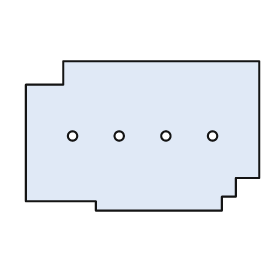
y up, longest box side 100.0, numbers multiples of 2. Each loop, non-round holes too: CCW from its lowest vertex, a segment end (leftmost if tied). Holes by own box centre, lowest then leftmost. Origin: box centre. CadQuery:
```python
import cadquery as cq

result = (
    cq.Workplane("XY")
    .moveTo(-20.0, -32.0)
    .lineTo(34.0, -32.0)
    .lineTo(34.0, -26.0)
    .lineTo(40.0, -26.0)
    .lineTo(40.0, -18.0)
    .lineTo(50.0, -18.0)
    .lineTo(50.0, 32.0)
    .lineTo(-34.0, 32.0)
    .lineTo(-34.0, 22.0)
    .lineTo(-50.0, 22.0)
    .lineTo(-50.0, -28.0)
    .lineTo(-20.0, -28.0)
    .close()
    .moveTo(-30.0, 0.0)
    .circle(2.0)
    .moveTo(-10.0, 0.0)
    .circle(2.0)
    .moveTo(10.0, 0.0)
    .circle(2.0)
    .moveTo(30.0, 0.0)
    .circle(2.0)
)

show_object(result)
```